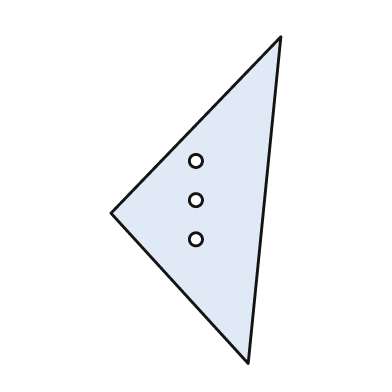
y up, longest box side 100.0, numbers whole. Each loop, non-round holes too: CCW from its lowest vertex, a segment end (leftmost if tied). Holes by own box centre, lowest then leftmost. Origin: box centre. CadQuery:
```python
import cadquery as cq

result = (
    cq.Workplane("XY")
    .moveTo(16.0, -50.0)
    .lineTo(26.0, 50.0)
    .lineTo(-26.0, -4.0)
    .close()
    .moveTo(0.0, -12.0)
    .circle(2.0)
    .moveTo(0.0, 0.0)
    .circle(2.0)
    .moveTo(0.0, 12.0)
    .circle(2.0)
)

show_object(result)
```